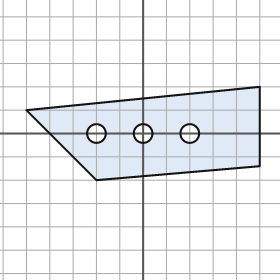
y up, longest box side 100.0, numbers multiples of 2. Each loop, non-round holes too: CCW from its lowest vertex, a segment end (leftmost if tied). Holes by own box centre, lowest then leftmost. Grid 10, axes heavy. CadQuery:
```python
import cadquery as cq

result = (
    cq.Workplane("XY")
    .moveTo(-20.0, -20.0)
    .lineTo(50.0, -14.0)
    .lineTo(50.0, 20.0)
    .lineTo(-50.0, 10.0)
    .close()
    .moveTo(-20.0, 0.0)
    .circle(4.0)
    .moveTo(0.0, 0.0)
    .circle(4.0)
    .moveTo(20.0, 0.0)
    .circle(4.0)
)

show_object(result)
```